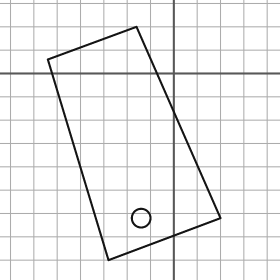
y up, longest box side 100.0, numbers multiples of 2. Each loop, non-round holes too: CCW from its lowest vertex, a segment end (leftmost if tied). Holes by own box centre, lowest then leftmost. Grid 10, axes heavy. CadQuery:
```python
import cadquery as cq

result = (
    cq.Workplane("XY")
    .moveTo(-28.0, -80.0)
    .lineTo(20.0, -62.0)
    .lineTo(-16.0, 20.0)
    .lineTo(-54.0, 6.0)
    .close()
    .moveTo(-14.0, -62.0)
    .circle(4.0)
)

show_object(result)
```